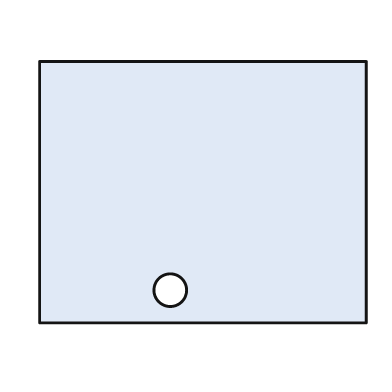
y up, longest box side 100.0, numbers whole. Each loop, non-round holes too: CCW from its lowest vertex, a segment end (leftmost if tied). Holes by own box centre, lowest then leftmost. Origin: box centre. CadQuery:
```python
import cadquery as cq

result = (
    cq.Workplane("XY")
    .moveTo(-50.0, -40.0)
    .lineTo(50.0, -40.0)
    .lineTo(50.0, 40.0)
    .lineTo(-50.0, 40.0)
    .close()
    .moveTo(-10.0, -30.0)
    .circle(5.0)
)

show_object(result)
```